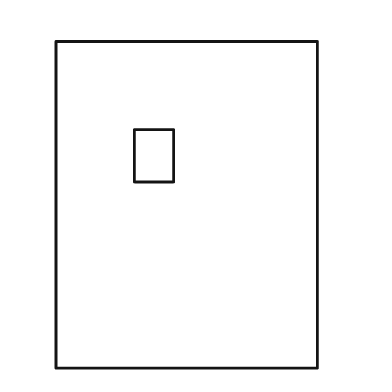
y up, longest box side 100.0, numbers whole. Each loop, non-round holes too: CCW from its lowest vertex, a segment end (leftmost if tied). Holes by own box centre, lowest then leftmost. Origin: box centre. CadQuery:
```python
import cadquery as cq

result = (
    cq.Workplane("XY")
    .moveTo(-40.0, -50.0)
    .lineTo(40.0, -50.0)
    .lineTo(40.0, 50.0)
    .lineTo(-40.0, 50.0)
    .close()
    .moveTo(-16.0, 7.0)
    .lineTo(-4.0, 7.0)
    .lineTo(-4.0, 23.0)
    .lineTo(-16.0, 23.0)
    .close()
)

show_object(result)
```